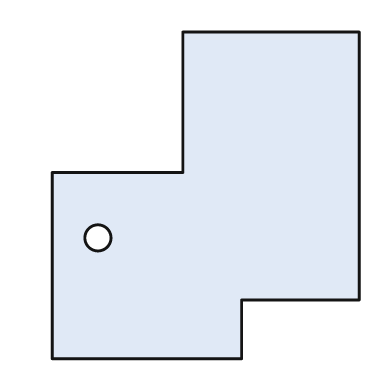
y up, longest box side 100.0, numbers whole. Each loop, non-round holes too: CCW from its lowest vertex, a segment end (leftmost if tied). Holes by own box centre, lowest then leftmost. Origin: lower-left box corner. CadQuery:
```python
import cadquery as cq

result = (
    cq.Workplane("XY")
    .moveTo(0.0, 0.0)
    .lineTo(58.0, 0.0)
    .lineTo(58.0, 18.0)
    .lineTo(94.0, 18.0)
    .lineTo(94.0, 100.0)
    .lineTo(40.0, 100.0)
    .lineTo(40.0, 57.0)
    .lineTo(0.0, 57.0)
    .close()
    .moveTo(14.0, 37.0)
    .circle(4.0)
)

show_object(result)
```